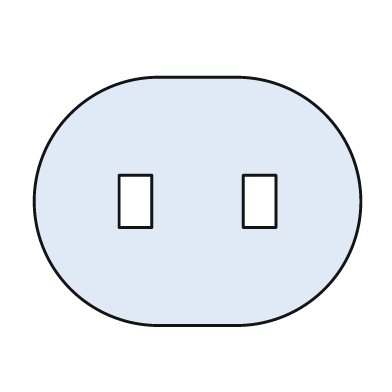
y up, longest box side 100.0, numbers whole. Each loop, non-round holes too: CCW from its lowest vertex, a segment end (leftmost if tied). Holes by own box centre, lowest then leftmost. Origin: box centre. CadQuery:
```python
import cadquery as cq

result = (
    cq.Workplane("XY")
    .moveTo(-12.0, -38.0)
    .lineTo(12.0, -38.0)
    .threePointArc((50.0, 0.0), (12.0, 38.0))
    .lineTo(-12.0, 38.0)
    .threePointArc((-50.0, 0.0), (-12.0, -38.0))
    .close()
    .moveTo(-24.0, -8.0)
    .lineTo(-14.0, -8.0)
    .lineTo(-14.0, 8.0)
    .lineTo(-24.0, 8.0)
    .close()
    .moveTo(14.0, -8.0)
    .lineTo(24.0, -8.0)
    .lineTo(24.0, 8.0)
    .lineTo(14.0, 8.0)
    .close()
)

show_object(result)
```